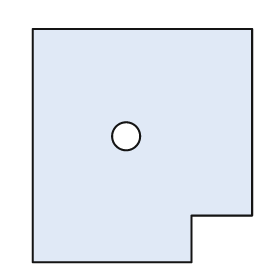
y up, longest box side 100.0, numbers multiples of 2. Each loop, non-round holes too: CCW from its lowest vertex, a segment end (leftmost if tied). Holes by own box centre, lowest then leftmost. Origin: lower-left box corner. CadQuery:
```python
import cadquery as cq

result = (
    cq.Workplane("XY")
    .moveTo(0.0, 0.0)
    .lineTo(68.0, 0.0)
    .lineTo(68.0, 20.0)
    .lineTo(94.0, 20.0)
    .lineTo(94.0, 100.0)
    .lineTo(0.0, 100.0)
    .close()
    .moveTo(40.0, 54.0)
    .circle(6.0)
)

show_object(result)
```